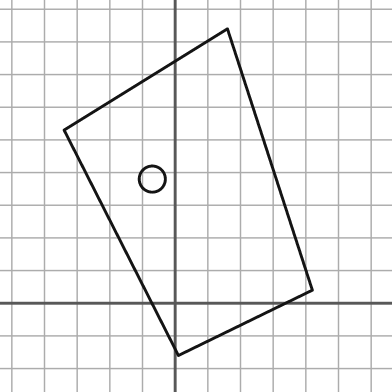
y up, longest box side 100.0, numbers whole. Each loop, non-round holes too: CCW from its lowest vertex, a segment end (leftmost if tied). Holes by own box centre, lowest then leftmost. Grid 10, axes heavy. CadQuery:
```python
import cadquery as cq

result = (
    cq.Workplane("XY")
    .moveTo(1.0, -16.0)
    .lineTo(42.0, 4.0)
    .lineTo(16.0, 84.0)
    .lineTo(-34.0, 53.0)
    .close()
    .moveTo(-7.0, 38.0)
    .circle(4.0)
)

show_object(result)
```